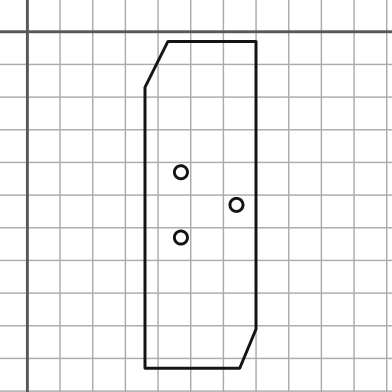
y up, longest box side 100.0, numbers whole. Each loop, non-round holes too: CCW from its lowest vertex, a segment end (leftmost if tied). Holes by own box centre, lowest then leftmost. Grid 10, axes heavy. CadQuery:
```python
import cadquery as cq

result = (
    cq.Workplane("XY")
    .moveTo(36.0, -103.0)
    .lineTo(65.0, -103.0)
    .lineTo(70.0, -91.0)
    .lineTo(70.0, -3.0)
    .lineTo(43.0, -3.0)
    .lineTo(36.0, -17.0)
    .close()
    .moveTo(47.0, -63.0)
    .circle(2.0)
    .moveTo(64.0, -53.0)
    .circle(2.0)
    .moveTo(47.0, -43.0)
    .circle(2.0)
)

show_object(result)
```